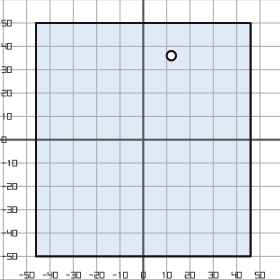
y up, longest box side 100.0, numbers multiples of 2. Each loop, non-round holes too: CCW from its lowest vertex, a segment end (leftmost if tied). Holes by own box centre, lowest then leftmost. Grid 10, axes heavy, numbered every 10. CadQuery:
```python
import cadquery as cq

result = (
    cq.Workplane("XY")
    .moveTo(-46.0, -50.0)
    .lineTo(46.0, -50.0)
    .lineTo(46.0, 50.0)
    .lineTo(-46.0, 50.0)
    .close()
    .moveTo(12.0, 36.0)
    .circle(2.0)
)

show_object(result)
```